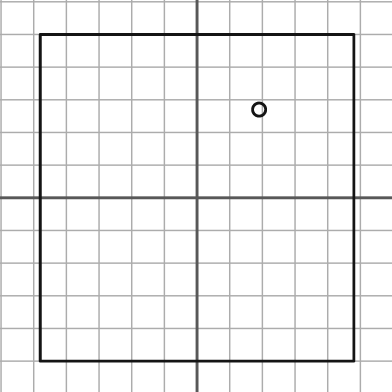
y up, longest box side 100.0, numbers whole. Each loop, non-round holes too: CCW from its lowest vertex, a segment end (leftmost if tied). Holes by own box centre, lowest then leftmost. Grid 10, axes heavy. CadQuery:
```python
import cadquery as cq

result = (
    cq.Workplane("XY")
    .moveTo(-48.0, -50.0)
    .lineTo(48.0, -50.0)
    .lineTo(48.0, 50.0)
    .lineTo(-48.0, 50.0)
    .close()
    .moveTo(19.0, 27.0)
    .circle(2.0)
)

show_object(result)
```